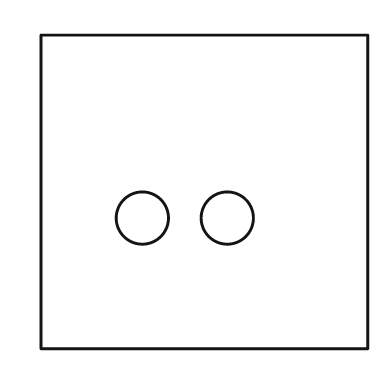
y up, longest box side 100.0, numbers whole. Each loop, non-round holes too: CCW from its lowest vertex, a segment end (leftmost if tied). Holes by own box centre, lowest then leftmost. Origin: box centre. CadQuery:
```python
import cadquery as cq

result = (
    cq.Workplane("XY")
    .moveTo(-50.0, -48.0)
    .lineTo(50.0, -48.0)
    .lineTo(50.0, 48.0)
    .lineTo(-50.0, 48.0)
    .close()
    .moveTo(-19.0, -8.0)
    .circle(8.0)
    .moveTo(7.0, -8.0)
    .circle(8.0)
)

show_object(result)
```